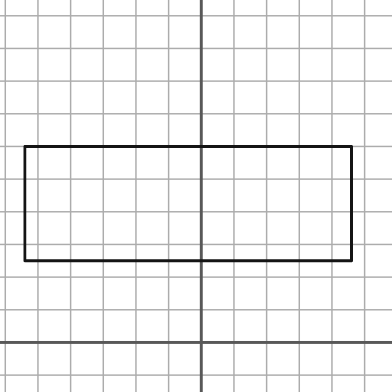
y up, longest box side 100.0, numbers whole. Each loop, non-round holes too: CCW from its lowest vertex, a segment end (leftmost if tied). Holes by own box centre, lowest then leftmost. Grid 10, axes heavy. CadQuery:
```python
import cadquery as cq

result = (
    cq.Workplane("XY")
    .moveTo(-54.0, 25.0)
    .lineTo(46.0, 25.0)
    .lineTo(46.0, 60.0)
    .lineTo(-54.0, 60.0)
    .close()
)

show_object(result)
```